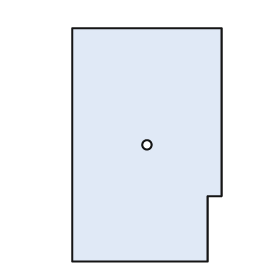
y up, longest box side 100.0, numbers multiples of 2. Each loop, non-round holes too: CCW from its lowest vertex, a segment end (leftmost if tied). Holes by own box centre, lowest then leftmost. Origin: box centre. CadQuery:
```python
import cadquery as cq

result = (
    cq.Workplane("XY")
    .moveTo(-32.0, -50.0)
    .lineTo(26.0, -50.0)
    .lineTo(26.0, -22.0)
    .lineTo(32.0, -22.0)
    .lineTo(32.0, 50.0)
    .lineTo(-32.0, 50.0)
    .close()
    .moveTo(0.0, 0.0)
    .circle(2.0)
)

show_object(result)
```